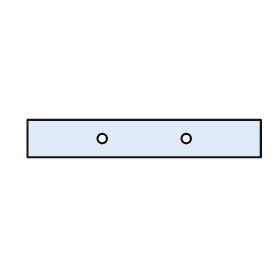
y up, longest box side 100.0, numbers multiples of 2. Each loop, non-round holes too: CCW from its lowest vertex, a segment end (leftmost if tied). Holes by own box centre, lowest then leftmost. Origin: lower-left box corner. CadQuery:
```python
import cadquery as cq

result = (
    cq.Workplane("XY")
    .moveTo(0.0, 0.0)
    .lineTo(100.0, 0.0)
    .lineTo(100.0, 16.0)
    .lineTo(0.0, 16.0)
    .close()
    .moveTo(32.0, 8.0)
    .circle(2.0)
    .moveTo(68.0, 8.0)
    .circle(2.0)
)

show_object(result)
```